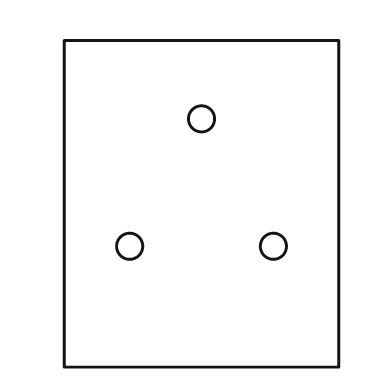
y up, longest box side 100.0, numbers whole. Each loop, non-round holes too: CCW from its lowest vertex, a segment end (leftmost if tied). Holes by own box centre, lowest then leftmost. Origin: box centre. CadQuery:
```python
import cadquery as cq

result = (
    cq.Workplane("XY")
    .moveTo(-42.0, -50.0)
    .lineTo(42.0, -50.0)
    .lineTo(42.0, 50.0)
    .lineTo(-42.0, 50.0)
    .close()
    .moveTo(-22.0, -13.0)
    .circle(4.0)
    .moveTo(22.0, -13.0)
    .circle(4.0)
    .moveTo(0.0, 26.0)
    .circle(4.0)
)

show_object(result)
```